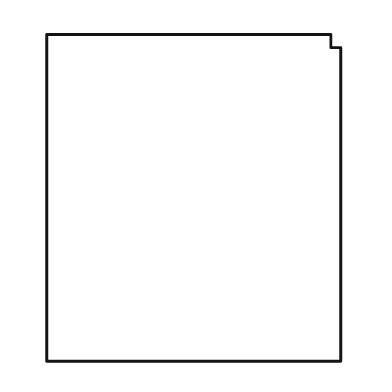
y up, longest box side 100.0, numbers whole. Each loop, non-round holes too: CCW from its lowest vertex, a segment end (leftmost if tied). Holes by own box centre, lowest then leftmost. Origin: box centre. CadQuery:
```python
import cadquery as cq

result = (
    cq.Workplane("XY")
    .moveTo(-45.0, -50.0)
    .lineTo(45.0, -50.0)
    .lineTo(45.0, 46.0)
    .lineTo(42.0, 46.0)
    .lineTo(42.0, 50.0)
    .lineTo(-45.0, 50.0)
    .close()
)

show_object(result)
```